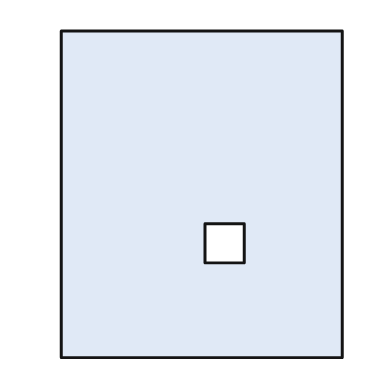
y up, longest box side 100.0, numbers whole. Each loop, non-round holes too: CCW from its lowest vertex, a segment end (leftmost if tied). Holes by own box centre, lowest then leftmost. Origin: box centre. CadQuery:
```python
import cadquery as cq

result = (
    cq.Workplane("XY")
    .moveTo(-43.0, -50.0)
    .lineTo(43.0, -50.0)
    .lineTo(43.0, 50.0)
    .lineTo(-43.0, 50.0)
    .close()
    .moveTo(1.0, -21.0)
    .lineTo(13.0, -21.0)
    .lineTo(13.0, -9.0)
    .lineTo(1.0, -9.0)
    .close()
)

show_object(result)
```